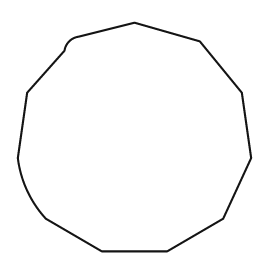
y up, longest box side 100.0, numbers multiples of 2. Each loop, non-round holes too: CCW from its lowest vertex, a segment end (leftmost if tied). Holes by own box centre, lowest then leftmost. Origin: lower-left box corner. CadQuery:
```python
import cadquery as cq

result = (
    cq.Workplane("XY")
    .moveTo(36.0, 0.0)
    .lineTo(64.0, 0.0)
    .lineTo(88.0, 14.0)
    .lineTo(100.0, 40.0)
    .lineTo(96.0, 68.0)
    .lineTo(78.0, 90.0)
    .lineTo(50.0, 98.0)
    .lineTo(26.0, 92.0)
    .threePointArc((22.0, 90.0), (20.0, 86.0))
    .lineTo(4.0, 68.0)
    .lineTo(0.0, 40.0)
    .threePointArc((4.0, 26.0), (12.0, 14.0))
    .close()
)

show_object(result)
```